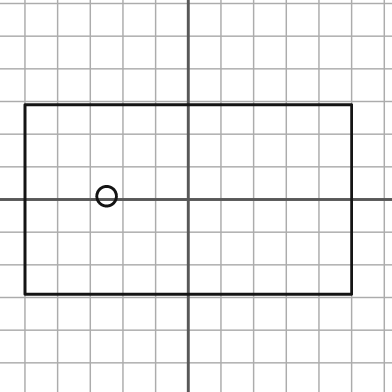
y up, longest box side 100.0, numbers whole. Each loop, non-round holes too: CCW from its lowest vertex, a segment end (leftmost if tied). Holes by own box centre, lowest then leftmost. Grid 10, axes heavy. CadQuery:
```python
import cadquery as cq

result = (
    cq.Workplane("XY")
    .moveTo(-50.0, -29.0)
    .lineTo(50.0, -29.0)
    .lineTo(50.0, 29.0)
    .lineTo(-50.0, 29.0)
    .close()
    .moveTo(-25.0, 1.0)
    .circle(3.0)
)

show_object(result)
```